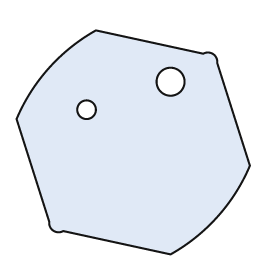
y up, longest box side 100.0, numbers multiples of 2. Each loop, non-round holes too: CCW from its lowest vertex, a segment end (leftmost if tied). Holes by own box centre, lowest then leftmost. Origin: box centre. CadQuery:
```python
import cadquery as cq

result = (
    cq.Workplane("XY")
    .moveTo(16.0, -48.0)
    .threePointArc((36.0, -32.0), (50.0, -10.0))
    .lineTo(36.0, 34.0)
    .threePointArc((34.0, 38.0), (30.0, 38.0))
    .lineTo(-16.0, 48.0)
    .threePointArc((-36.0, 32.0), (-50.0, 10.0))
    .lineTo(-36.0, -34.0)
    .threePointArc((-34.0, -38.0), (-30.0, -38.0))
    .close()
    .moveTo(-20.0, 14.0)
    .circle(4.0)
    .moveTo(16.0, 26.0)
    .circle(6.0)
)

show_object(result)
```